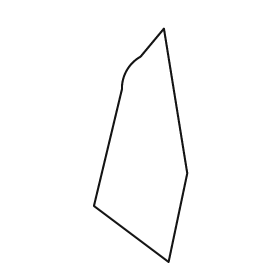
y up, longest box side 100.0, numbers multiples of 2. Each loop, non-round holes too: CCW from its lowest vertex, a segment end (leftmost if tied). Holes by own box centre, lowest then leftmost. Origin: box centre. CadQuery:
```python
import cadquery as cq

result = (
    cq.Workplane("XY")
    .moveTo(12.0, -50.0)
    .lineTo(20.0, -12.0)
    .lineTo(10.0, 50.0)
    .lineTo(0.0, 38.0)
    .threePointArc((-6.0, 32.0), (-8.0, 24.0))
    .lineTo(-20.0, -26.0)
    .close()
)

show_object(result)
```